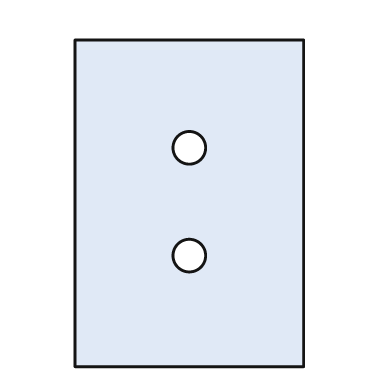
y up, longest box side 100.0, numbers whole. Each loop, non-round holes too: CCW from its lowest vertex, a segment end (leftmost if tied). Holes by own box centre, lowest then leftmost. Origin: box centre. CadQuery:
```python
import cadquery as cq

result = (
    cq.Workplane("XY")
    .moveTo(-35.0, -50.0)
    .lineTo(35.0, -50.0)
    .lineTo(35.0, 50.0)
    .lineTo(-35.0, 50.0)
    .close()
    .moveTo(0.0, -16.0)
    .circle(5.0)
    .moveTo(0.0, 17.0)
    .circle(5.0)
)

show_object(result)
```